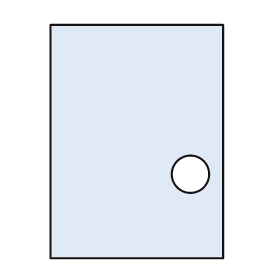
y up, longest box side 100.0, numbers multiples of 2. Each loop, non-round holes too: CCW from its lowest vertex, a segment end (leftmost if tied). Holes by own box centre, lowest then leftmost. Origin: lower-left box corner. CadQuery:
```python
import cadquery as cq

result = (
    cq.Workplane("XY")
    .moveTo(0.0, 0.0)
    .lineTo(74.0, 0.0)
    .lineTo(74.0, 100.0)
    .lineTo(0.0, 100.0)
    .close()
    .moveTo(60.0, 36.0)
    .circle(8.0)
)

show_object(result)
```